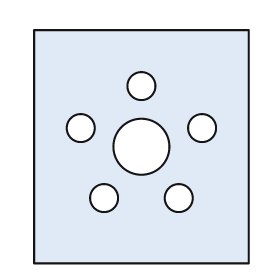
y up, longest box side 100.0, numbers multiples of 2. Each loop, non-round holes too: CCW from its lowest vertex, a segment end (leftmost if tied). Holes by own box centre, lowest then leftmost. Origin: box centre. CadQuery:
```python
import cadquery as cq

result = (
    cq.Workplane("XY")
    .moveTo(-46.0, -50.0)
    .lineTo(46.0, -50.0)
    .lineTo(46.0, 50.0)
    .lineTo(-46.0, 50.0)
    .close()
    .moveTo(-16.0, -22.0)
    .circle(6.0)
    .moveTo(16.0, -22.0)
    .circle(6.0)
    .moveTo(0.0, 0.0)
    .circle(12.0)
    .moveTo(-26.0, 8.0)
    .circle(6.0)
    .moveTo(26.0, 8.0)
    .circle(6.0)
    .moveTo(0.0, 26.0)
    .circle(6.0)
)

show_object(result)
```